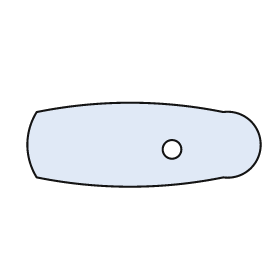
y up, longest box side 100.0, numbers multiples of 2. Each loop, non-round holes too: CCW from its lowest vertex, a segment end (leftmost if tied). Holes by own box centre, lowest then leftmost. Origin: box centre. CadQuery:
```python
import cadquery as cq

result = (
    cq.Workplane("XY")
    .moveTo(-46.0, -14.0)
    .threePointArc((-6.0, -18.0), (34.0, -14.0))
    .threePointArc((50.0, 0.0), (34.0, 14.0))
    .threePointArc((-6.0, 18.0), (-46.0, 14.0))
    .threePointArc((-50.0, 0.0), (-46.0, -14.0))
    .close()
    .moveTo(12.0, -2.0)
    .circle(4.0)
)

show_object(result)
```